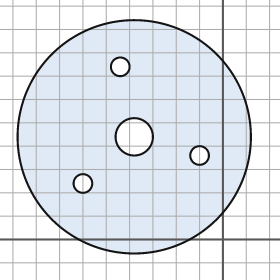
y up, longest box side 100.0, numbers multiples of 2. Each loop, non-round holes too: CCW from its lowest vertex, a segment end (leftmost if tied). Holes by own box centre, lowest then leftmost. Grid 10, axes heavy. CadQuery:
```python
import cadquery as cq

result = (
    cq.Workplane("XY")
    .moveTo(-38.0, 44.0)
    .circle(50.0)
    .moveTo(-60.0, 24.0)
    .circle(4.0)
    .moveTo(-10.0, 36.0)
    .circle(4.0)
    .moveTo(-38.0, 44.0)
    .circle(8.0)
    .moveTo(-44.0, 74.0)
    .circle(4.0)
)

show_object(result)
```